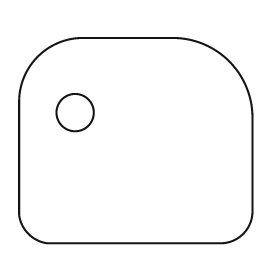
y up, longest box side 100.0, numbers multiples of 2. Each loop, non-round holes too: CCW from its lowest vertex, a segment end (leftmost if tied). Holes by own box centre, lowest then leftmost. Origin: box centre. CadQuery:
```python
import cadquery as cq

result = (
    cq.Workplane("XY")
    .moveTo(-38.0, -44.0)
    .lineTo(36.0, -44.0)
    .threePointArc((46.0, -40.0), (50.0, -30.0))
    .lineTo(50.0, 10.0)
    .threePointArc((40.0, 34.0), (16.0, 44.0))
    .lineTo(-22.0, 44.0)
    .threePointArc((-42.0, 36.0), (-50.0, 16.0))
    .lineTo(-50.0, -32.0)
    .threePointArc((-46.0, -40.0), (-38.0, -44.0))
    .close()
    .moveTo(-26.0, 12.0)
    .circle(8.0)
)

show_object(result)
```